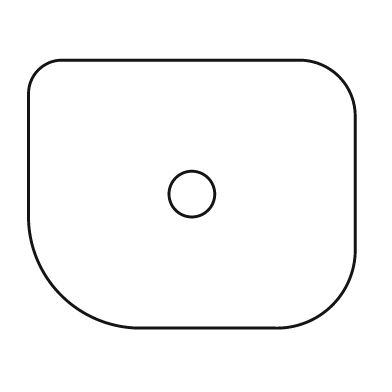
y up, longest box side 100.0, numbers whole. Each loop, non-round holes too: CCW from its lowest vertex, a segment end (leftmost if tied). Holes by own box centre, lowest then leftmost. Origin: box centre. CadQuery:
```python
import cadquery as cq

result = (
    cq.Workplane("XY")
    .moveTo(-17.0, -41.0)
    .lineTo(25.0, -41.0)
    .threePointArc((43.0, -34.0), (50.0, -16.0))
    .lineTo(50.0, 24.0)
    .threePointArc((45.0, 36.0), (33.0, 41.0))
    .lineTo(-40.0, 41.0)
    .threePointArc((-47.0, 38.0), (-50.0, 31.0))
    .lineTo(-50.0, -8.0)
    .threePointArc((-40.0, -31.0), (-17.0, -41.0))
    .close()
    .moveTo(0.0, 0.0)
    .circle(7.0)
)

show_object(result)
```